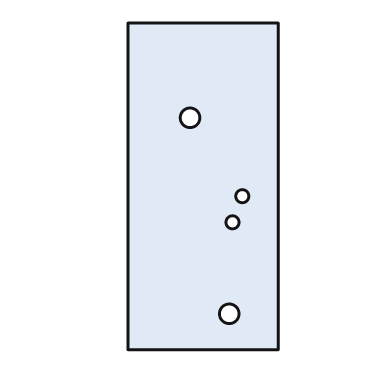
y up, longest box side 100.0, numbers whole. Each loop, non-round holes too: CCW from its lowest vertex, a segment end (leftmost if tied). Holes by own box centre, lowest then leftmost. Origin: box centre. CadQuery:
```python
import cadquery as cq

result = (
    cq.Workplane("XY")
    .moveTo(-23.0, -50.0)
    .lineTo(23.0, -50.0)
    .lineTo(23.0, 50.0)
    .lineTo(-23.0, 50.0)
    .close()
    .moveTo(8.0, -39.0)
    .circle(3.0)
    .moveTo(9.0, -11.0)
    .circle(2.0)
    .moveTo(12.0, -3.0)
    .circle(2.0)
    .moveTo(-4.0, 21.0)
    .circle(3.0)
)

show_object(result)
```